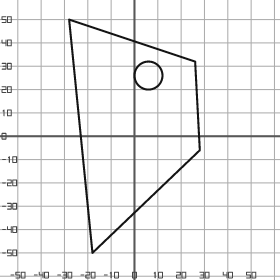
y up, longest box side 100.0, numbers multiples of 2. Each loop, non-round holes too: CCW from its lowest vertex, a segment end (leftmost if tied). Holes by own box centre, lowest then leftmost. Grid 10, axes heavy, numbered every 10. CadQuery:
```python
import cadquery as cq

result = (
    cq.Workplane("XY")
    .moveTo(-18.0, -50.0)
    .lineTo(28.0, -6.0)
    .lineTo(26.0, 32.0)
    .lineTo(-28.0, 50.0)
    .close()
    .moveTo(6.0, 26.0)
    .circle(6.0)
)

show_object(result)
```